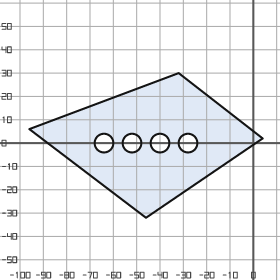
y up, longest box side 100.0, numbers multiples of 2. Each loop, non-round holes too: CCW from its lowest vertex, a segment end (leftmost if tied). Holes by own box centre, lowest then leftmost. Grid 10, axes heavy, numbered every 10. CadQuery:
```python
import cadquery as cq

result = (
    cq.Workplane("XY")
    .moveTo(-46.0, -32.0)
    .lineTo(4.0, 2.0)
    .lineTo(-32.0, 30.0)
    .lineTo(-96.0, 6.0)
    .close()
    .moveTo(-64.0, 0.0)
    .circle(4.0)
    .moveTo(-52.0, 0.0)
    .circle(4.0)
    .moveTo(-40.0, 0.0)
    .circle(4.0)
    .moveTo(-28.0, 0.0)
    .circle(4.0)
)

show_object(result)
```